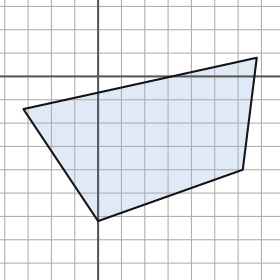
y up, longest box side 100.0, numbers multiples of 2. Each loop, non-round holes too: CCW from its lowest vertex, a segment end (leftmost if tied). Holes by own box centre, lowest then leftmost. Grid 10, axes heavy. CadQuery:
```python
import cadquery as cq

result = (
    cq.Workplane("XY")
    .moveTo(0.0, -62.0)
    .lineTo(62.0, -40.0)
    .lineTo(68.0, 8.0)
    .lineTo(-32.0, -14.0)
    .close()
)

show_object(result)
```